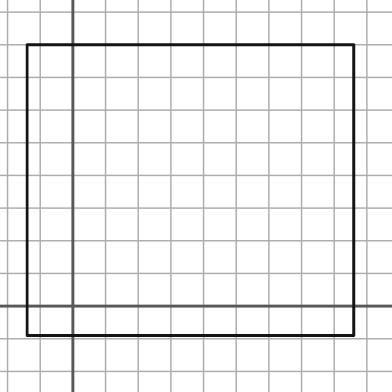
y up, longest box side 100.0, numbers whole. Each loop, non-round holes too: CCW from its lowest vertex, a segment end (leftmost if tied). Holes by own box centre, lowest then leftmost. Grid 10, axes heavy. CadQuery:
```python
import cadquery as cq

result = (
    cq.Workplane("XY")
    .moveTo(-14.0, -9.0)
    .lineTo(86.0, -9.0)
    .lineTo(86.0, 80.0)
    .lineTo(-14.0, 80.0)
    .close()
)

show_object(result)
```